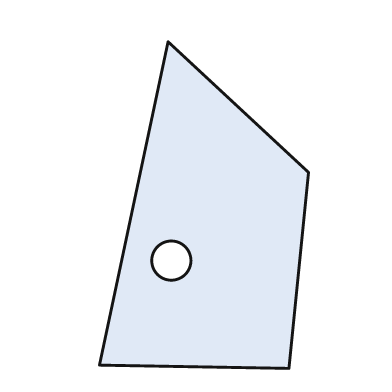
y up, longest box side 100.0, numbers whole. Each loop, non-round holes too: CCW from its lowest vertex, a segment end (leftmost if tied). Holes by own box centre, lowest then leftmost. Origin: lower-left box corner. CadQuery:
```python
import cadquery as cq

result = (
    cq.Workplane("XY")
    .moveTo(58.0, 0.0)
    .lineTo(64.0, 60.0)
    .lineTo(21.0, 100.0)
    .lineTo(0.0, 1.0)
    .close()
    .moveTo(22.0, 33.0)
    .circle(6.0)
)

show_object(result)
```